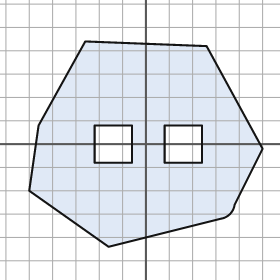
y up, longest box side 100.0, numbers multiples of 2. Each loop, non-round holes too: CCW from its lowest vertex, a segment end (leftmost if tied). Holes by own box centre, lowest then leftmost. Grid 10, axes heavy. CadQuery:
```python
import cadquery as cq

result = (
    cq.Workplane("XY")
    .moveTo(-16.0, -44.0)
    .lineTo(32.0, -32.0)
    .threePointArc((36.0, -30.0), (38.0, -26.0))
    .lineTo(50.0, -2.0)
    .lineTo(26.0, 42.0)
    .lineTo(-26.0, 44.0)
    .lineTo(-46.0, 8.0)
    .lineTo(-50.0, -20.0)
    .close()
    .moveTo(-22.0, -8.0)
    .lineTo(-6.0, -8.0)
    .lineTo(-6.0, 8.0)
    .lineTo(-22.0, 8.0)
    .close()
    .moveTo(8.0, -8.0)
    .lineTo(24.0, -8.0)
    .lineTo(24.0, 8.0)
    .lineTo(8.0, 8.0)
    .close()
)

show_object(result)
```